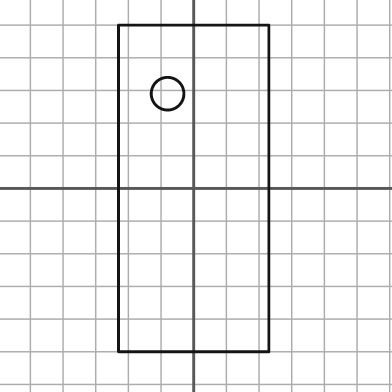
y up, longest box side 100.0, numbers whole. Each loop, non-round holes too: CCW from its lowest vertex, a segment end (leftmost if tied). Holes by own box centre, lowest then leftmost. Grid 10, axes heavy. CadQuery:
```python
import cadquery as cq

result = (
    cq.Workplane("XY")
    .moveTo(-23.0, -50.0)
    .lineTo(23.0, -50.0)
    .lineTo(23.0, 50.0)
    .lineTo(-23.0, 50.0)
    .close()
    .moveTo(-8.0, 29.0)
    .circle(5.0)
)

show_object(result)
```